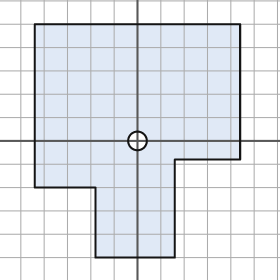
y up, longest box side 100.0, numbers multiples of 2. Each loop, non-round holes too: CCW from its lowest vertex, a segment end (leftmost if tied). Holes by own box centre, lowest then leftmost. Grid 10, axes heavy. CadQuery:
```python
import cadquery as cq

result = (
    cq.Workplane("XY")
    .moveTo(-18.0, -50.0)
    .lineTo(16.0, -50.0)
    .lineTo(16.0, -8.0)
    .lineTo(44.0, -8.0)
    .lineTo(44.0, 50.0)
    .lineTo(-44.0, 50.0)
    .lineTo(-44.0, -20.0)
    .lineTo(-18.0, -20.0)
    .close()
    .moveTo(0.0, 0.0)
    .circle(4.0)
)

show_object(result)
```